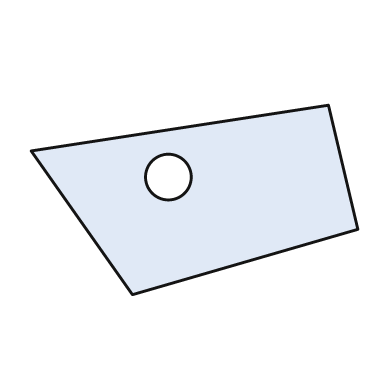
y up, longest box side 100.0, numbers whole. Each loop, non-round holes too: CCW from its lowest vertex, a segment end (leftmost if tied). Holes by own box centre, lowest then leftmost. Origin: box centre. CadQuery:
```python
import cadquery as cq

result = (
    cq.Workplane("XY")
    .moveTo(-19.0, -29.0)
    .lineTo(50.0, -9.0)
    .lineTo(41.0, 29.0)
    .lineTo(-50.0, 15.0)
    .close()
    .moveTo(-8.0, 7.0)
    .circle(7.0)
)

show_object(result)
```